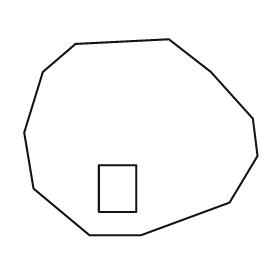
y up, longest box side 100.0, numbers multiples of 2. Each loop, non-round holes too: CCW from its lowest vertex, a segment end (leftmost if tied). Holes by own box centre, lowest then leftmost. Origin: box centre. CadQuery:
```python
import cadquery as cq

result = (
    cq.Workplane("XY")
    .moveTo(-22.0, -42.0)
    .lineTo(0.0, -42.0)
    .lineTo(38.0, -28.0)
    .lineTo(50.0, -8.0)
    .lineTo(48.0, 8.0)
    .lineTo(30.0, 28.0)
    .lineTo(12.0, 42.0)
    .lineTo(-28.0, 40.0)
    .lineTo(-42.0, 28.0)
    .lineTo(-50.0, 2.0)
    .lineTo(-46.0, -22.0)
    .close()
    .moveTo(-18.0, -32.0)
    .lineTo(-2.0, -32.0)
    .lineTo(-2.0, -12.0)
    .lineTo(-18.0, -12.0)
    .close()
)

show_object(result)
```